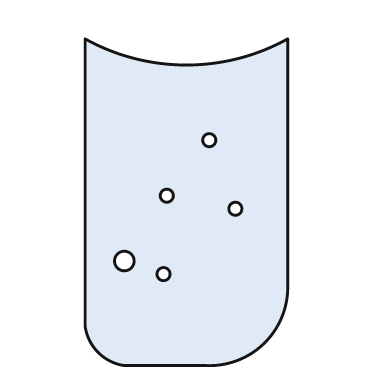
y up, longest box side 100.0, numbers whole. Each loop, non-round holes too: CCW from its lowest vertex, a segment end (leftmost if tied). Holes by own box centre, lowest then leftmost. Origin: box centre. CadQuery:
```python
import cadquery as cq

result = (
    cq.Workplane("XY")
    .moveTo(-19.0, -50.0)
    .lineTo(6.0, -50.0)
    .threePointArc((24.0, -43.0), (31.0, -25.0))
    .lineTo(31.0, 50.0)
    .threePointArc((0.0, 42.0), (-31.0, 50.0))
    .lineTo(-31.0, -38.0)
    .threePointArc((-27.0, -46.0), (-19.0, -50.0))
    .close()
    .moveTo(-7.0, -22.0)
    .circle(2.0)
    .moveTo(-19.0, -18.0)
    .circle(3.0)
    .moveTo(15.0, -2.0)
    .circle(2.0)
    .moveTo(-6.0, 2.0)
    .circle(2.0)
    .moveTo(7.0, 19.0)
    .circle(2.0)
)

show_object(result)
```